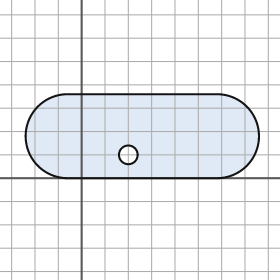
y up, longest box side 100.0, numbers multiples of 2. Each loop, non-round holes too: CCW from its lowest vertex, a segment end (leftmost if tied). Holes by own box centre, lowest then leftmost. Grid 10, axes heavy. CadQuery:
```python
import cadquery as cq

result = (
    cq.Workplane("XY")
    .moveTo(-6.0, 0.0)
    .lineTo(58.0, 0.0)
    .threePointArc((76.0, 18.0), (58.0, 36.0))
    .lineTo(-6.0, 36.0)
    .threePointArc((-24.0, 18.0), (-6.0, 0.0))
    .close()
    .moveTo(20.0, 10.0)
    .circle(4.0)
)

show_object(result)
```